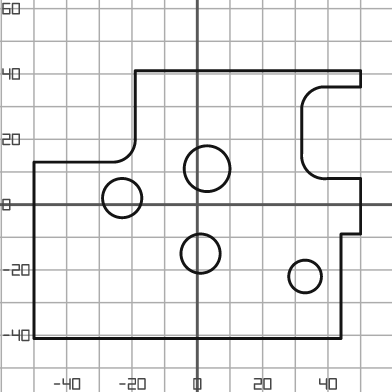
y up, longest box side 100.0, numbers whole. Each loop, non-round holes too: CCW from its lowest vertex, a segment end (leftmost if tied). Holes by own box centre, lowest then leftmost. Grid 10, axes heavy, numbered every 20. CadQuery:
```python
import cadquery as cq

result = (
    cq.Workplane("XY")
    .moveTo(-50.0, -41.0)
    .lineTo(44.0, -41.0)
    .lineTo(44.0, -9.0)
    .lineTo(50.0, -9.0)
    .lineTo(50.0, 8.0)
    .lineTo(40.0, 8.0)
    .threePointArc((34.0, 10.0), (32.0, 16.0))
    .lineTo(32.0, 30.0)
    .threePointArc((34.0, 34.0), (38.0, 36.0))
    .lineTo(50.0, 36.0)
    .lineTo(50.0, 41.0)
    .lineTo(-19.0, 41.0)
    .lineTo(-19.0, 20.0)
    .threePointArc((-21.0, 15.0), (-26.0, 13.0))
    .lineTo(-50.0, 13.0)
    .close()
    .moveTo(33.0, -22.0)
    .circle(5.0)
    .moveTo(1.0, -15.0)
    .circle(6.0)
    .moveTo(-23.0, 2.0)
    .circle(6.0)
    .moveTo(3.0, 11.0)
    .circle(7.0)
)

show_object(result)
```